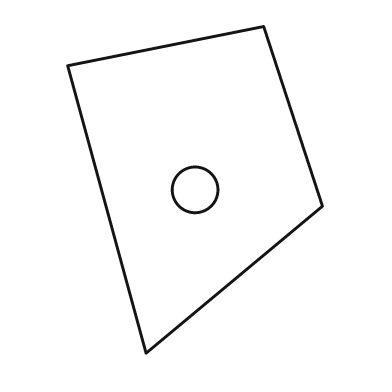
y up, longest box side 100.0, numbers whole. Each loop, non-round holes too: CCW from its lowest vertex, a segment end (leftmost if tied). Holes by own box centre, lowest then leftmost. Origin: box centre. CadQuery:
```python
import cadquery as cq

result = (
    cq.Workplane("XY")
    .moveTo(-15.0, -50.0)
    .lineTo(39.0, -5.0)
    .lineTo(21.0, 50.0)
    .lineTo(-39.0, 38.0)
    .close()
    .moveTo(0.0, 0.0)
    .circle(7.0)
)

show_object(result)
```